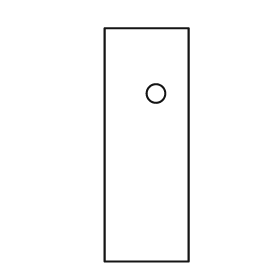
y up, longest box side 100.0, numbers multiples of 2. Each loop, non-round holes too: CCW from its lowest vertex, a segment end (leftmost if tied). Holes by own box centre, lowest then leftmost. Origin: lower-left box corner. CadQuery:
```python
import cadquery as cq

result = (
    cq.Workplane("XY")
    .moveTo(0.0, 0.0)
    .lineTo(36.0, 0.0)
    .lineTo(36.0, 100.0)
    .lineTo(0.0, 100.0)
    .close()
    .moveTo(22.0, 72.0)
    .circle(4.0)
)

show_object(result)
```